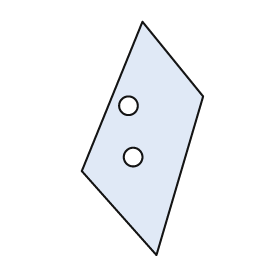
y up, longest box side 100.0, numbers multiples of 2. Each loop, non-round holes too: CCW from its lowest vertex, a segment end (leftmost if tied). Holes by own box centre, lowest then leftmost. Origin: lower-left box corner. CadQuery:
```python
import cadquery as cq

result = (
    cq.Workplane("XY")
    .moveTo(32.0, 0.0)
    .lineTo(52.0, 68.0)
    .lineTo(26.0, 100.0)
    .lineTo(0.0, 36.0)
    .close()
    .moveTo(22.0, 42.0)
    .circle(4.0)
    .moveTo(20.0, 64.0)
    .circle(4.0)
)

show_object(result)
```